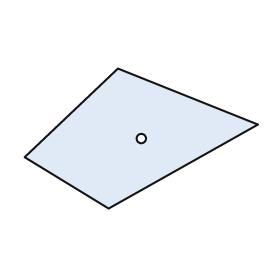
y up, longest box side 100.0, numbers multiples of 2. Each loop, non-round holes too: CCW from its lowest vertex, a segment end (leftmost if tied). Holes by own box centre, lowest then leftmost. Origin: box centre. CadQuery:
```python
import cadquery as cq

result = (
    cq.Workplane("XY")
    .moveTo(-14.0, -30.0)
    .lineTo(50.0, 6.0)
    .lineTo(-10.0, 30.0)
    .lineTo(-50.0, -8.0)
    .close()
    .moveTo(0.0, 0.0)
    .circle(2.0)
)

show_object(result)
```